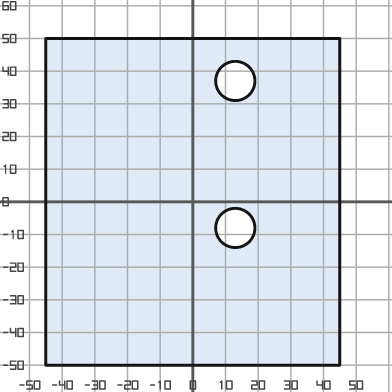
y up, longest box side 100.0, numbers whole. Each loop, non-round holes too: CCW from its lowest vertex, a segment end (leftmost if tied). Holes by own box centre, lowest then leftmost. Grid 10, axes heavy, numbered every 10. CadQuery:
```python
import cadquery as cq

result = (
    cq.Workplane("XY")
    .moveTo(-45.0, -50.0)
    .lineTo(45.0, -50.0)
    .lineTo(45.0, 50.0)
    .lineTo(-45.0, 50.0)
    .close()
    .moveTo(13.0, -8.0)
    .circle(6.0)
    .moveTo(13.0, 37.0)
    .circle(6.0)
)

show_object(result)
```